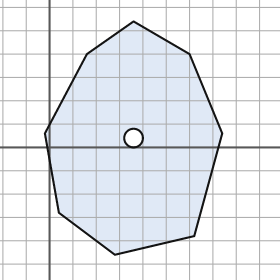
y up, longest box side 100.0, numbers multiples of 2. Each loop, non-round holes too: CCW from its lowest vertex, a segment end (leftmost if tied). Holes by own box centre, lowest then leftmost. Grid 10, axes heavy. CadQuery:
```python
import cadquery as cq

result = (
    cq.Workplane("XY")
    .moveTo(28.0, -46.0)
    .lineTo(62.0, -38.0)
    .lineTo(74.0, 6.0)
    .lineTo(60.0, 40.0)
    .lineTo(36.0, 54.0)
    .lineTo(16.0, 40.0)
    .lineTo(-2.0, 6.0)
    .lineTo(4.0, -28.0)
    .close()
    .moveTo(36.0, 4.0)
    .circle(4.0)
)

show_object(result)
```